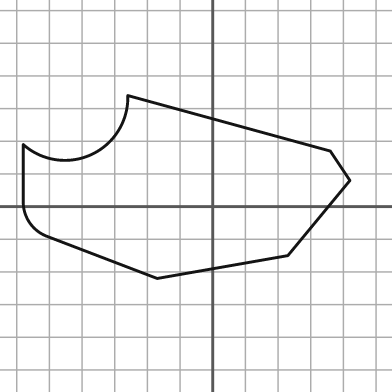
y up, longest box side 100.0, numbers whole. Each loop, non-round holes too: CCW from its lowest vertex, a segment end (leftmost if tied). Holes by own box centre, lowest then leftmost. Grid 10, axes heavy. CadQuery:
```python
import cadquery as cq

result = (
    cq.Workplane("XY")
    .moveTo(-17.0, -22.0)
    .lineTo(23.0, -15.0)
    .lineTo(42.0, 8.0)
    .lineTo(36.0, 17.0)
    .lineTo(-26.0, 34.0)
    .threePointArc((-37.0, 16.0), (-58.0, 19.0))
    .lineTo(-58.0, 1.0)
    .threePointArc((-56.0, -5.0), (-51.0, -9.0))
    .close()
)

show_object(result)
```